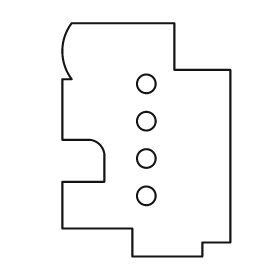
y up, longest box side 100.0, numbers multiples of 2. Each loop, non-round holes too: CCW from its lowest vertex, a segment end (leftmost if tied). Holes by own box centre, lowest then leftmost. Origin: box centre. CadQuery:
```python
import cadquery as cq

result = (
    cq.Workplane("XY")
    .moveTo(-6.0, -50.0)
    .lineTo(24.0, -50.0)
    .lineTo(24.0, -44.0)
    .lineTo(36.0, -44.0)
    .lineTo(36.0, 30.0)
    .lineTo(12.0, 30.0)
    .lineTo(12.0, 50.0)
    .lineTo(-32.0, 50.0)
    .threePointArc((-36.0, 38.0), (-32.0, 26.0))
    .lineTo(-36.0, 26.0)
    .lineTo(-36.0, 0.0)
    .lineTo(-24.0, 0.0)
    .threePointArc((-20.0, -2.0), (-18.0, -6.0))
    .lineTo(-18.0, -18.0)
    .lineTo(-36.0, -18.0)
    .lineTo(-36.0, -38.0)
    .lineTo(-6.0, -38.0)
    .close()
    .moveTo(0.0, -24.0)
    .circle(4.0)
    .moveTo(0.0, -8.0)
    .circle(4.0)
    .moveTo(0.0, 8.0)
    .circle(4.0)
    .moveTo(0.0, 24.0)
    .circle(4.0)
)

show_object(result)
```